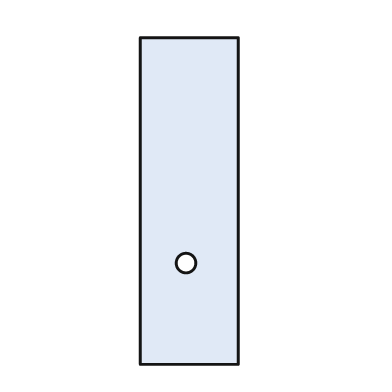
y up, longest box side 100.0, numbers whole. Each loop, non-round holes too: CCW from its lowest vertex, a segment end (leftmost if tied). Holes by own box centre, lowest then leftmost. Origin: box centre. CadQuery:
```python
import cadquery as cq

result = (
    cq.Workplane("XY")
    .moveTo(-15.0, -50.0)
    .lineTo(15.0, -50.0)
    .lineTo(15.0, 50.0)
    .lineTo(-15.0, 50.0)
    .close()
    .moveTo(-1.0, -19.0)
    .circle(3.0)
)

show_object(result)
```